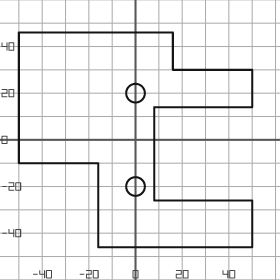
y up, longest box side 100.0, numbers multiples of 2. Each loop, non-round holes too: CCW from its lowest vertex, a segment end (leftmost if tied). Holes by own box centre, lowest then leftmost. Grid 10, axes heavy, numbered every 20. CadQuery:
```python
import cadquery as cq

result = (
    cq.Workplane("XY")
    .moveTo(-16.0, -46.0)
    .lineTo(50.0, -46.0)
    .lineTo(50.0, -26.0)
    .lineTo(8.0, -26.0)
    .lineTo(8.0, 14.0)
    .lineTo(50.0, 14.0)
    .lineTo(50.0, 30.0)
    .lineTo(16.0, 30.0)
    .lineTo(16.0, 46.0)
    .lineTo(-50.0, 46.0)
    .lineTo(-50.0, -10.0)
    .lineTo(-16.0, -10.0)
    .close()
    .moveTo(0.0, -20.0)
    .circle(4.0)
    .moveTo(0.0, 20.0)
    .circle(4.0)
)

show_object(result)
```